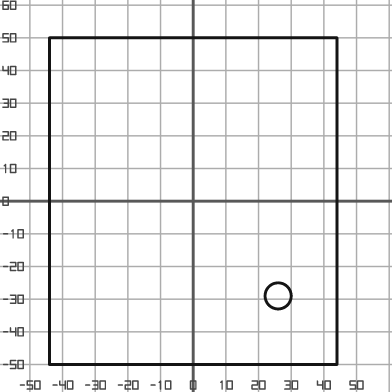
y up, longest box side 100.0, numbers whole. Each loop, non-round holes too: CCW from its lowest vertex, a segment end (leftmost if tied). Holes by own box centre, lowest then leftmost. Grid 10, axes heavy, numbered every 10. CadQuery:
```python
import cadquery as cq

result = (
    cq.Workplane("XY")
    .moveTo(-44.0, -50.0)
    .lineTo(44.0, -50.0)
    .lineTo(44.0, 50.0)
    .lineTo(-44.0, 50.0)
    .close()
    .moveTo(26.0, -29.0)
    .circle(4.0)
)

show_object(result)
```